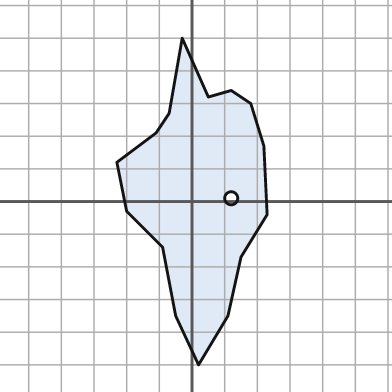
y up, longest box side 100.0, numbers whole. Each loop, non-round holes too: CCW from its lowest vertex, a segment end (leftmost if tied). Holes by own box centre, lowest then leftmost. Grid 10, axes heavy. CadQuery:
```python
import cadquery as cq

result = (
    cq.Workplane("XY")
    .moveTo(2.0, -50.0)
    .lineTo(11.0, -35.0)
    .lineTo(15.0, -17.0)
    .lineTo(23.0, -4.0)
    .lineTo(22.0, 17.0)
    .lineTo(18.0, 30.0)
    .lineTo(12.0, 34.0)
    .lineTo(5.0, 32.0)
    .lineTo(-3.0, 50.0)
    .lineTo(-7.0, 27.0)
    .lineTo(-11.0, 21.0)
    .lineTo(-23.0, 12.0)
    .lineTo(-20.0, -3.0)
    .lineTo(-9.0, -14.0)
    .lineTo(-5.0, -35.0)
    .close()
    .moveTo(12.0, 1.0)
    .circle(2.0)
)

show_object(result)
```